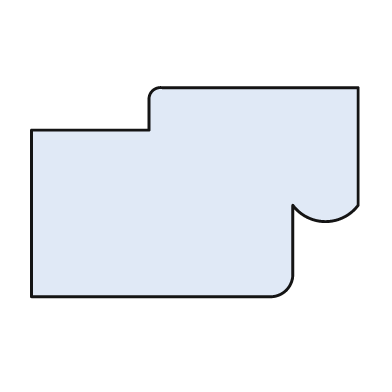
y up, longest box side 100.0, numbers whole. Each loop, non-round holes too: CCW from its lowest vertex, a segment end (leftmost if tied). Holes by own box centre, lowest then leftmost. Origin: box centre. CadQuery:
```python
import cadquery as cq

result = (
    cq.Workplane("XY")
    .moveTo(-50.0, -32.0)
    .lineTo(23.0, -32.0)
    .threePointArc((28.0, -30.0), (30.0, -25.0))
    .lineTo(30.0, -4.0)
    .threePointArc((40.0, -9.0), (50.0, -4.0))
    .lineTo(50.0, 32.0)
    .lineTo(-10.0, 32.0)
    .threePointArc((-13.0, 31.0), (-14.0, 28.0))
    .lineTo(-14.0, 19.0)
    .lineTo(-50.0, 19.0)
    .close()
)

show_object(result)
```